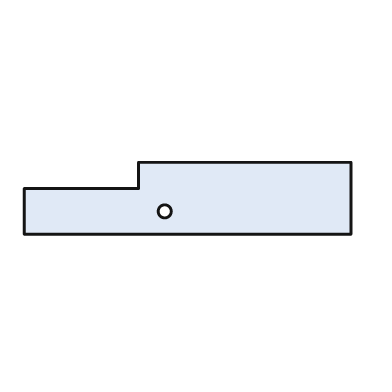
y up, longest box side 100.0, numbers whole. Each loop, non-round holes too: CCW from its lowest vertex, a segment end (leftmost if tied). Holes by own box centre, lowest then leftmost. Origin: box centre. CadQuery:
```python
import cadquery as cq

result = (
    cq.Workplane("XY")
    .moveTo(-50.0, -11.0)
    .lineTo(50.0, -11.0)
    .lineTo(50.0, 11.0)
    .lineTo(-15.0, 11.0)
    .lineTo(-15.0, 3.0)
    .lineTo(-50.0, 3.0)
    .close()
    .moveTo(-7.0, -4.0)
    .circle(2.0)
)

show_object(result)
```